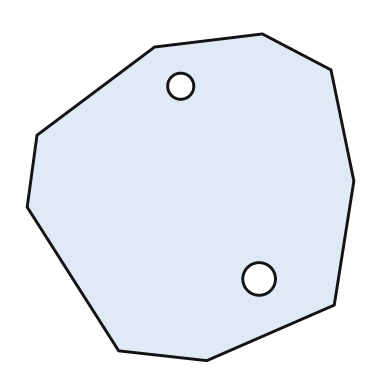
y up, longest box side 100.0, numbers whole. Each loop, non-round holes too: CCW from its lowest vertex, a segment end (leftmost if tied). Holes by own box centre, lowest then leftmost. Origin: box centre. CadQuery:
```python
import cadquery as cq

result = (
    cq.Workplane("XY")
    .moveTo(5.0, -50.0)
    .lineTo(44.0, -33.0)
    .lineTo(50.0, 5.0)
    .lineTo(43.0, 39.0)
    .lineTo(22.0, 50.0)
    .lineTo(-11.0, 46.0)
    .lineTo(-47.0, 19.0)
    .lineTo(-50.0, -3.0)
    .lineTo(-22.0, -47.0)
    .close()
    .moveTo(21.0, -25.0)
    .circle(5.0)
    .moveTo(-3.0, 34.0)
    .circle(4.0)
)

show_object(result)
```